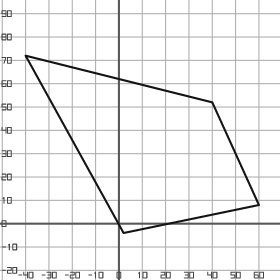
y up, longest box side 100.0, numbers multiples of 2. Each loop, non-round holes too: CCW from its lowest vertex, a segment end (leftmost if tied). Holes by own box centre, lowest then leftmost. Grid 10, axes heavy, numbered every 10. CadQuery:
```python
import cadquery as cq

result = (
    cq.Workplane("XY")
    .moveTo(2.0, -4.0)
    .lineTo(60.0, 8.0)
    .lineTo(40.0, 52.0)
    .lineTo(-40.0, 72.0)
    .close()
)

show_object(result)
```